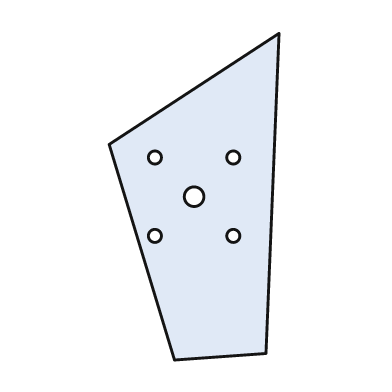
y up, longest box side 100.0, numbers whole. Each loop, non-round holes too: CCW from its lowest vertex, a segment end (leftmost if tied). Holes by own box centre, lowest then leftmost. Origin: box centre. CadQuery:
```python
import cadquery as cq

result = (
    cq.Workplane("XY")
    .moveTo(-6.0, -50.0)
    .lineTo(22.0, -48.0)
    .lineTo(26.0, 50.0)
    .lineTo(-26.0, 16.0)
    .close()
    .moveTo(-12.0, -12.0)
    .circle(2.0)
    .moveTo(12.0, -12.0)
    .circle(2.0)
    .moveTo(0.0, 0.0)
    .circle(3.0)
    .moveTo(-12.0, 12.0)
    .circle(2.0)
    .moveTo(12.0, 12.0)
    .circle(2.0)
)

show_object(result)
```